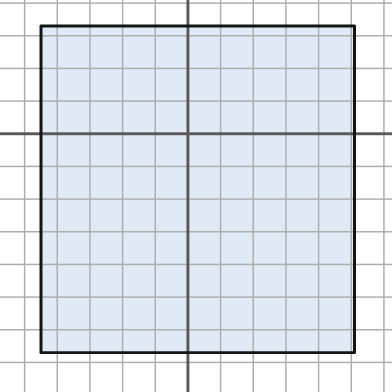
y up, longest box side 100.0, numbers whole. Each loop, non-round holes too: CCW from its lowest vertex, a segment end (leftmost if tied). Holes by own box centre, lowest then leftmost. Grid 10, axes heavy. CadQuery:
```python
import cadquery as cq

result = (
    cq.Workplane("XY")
    .moveTo(-45.0, -67.0)
    .lineTo(51.0, -67.0)
    .lineTo(51.0, 33.0)
    .lineTo(-45.0, 33.0)
    .close()
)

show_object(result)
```